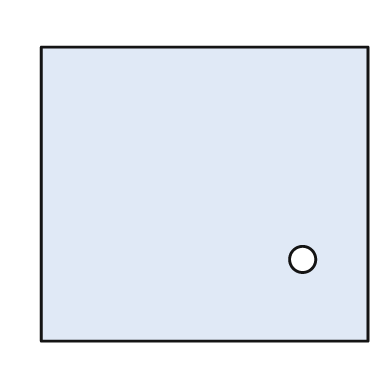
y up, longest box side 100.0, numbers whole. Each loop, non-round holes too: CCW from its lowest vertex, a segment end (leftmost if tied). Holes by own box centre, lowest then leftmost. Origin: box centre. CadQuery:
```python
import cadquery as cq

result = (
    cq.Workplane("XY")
    .moveTo(-50.0, -45.0)
    .lineTo(50.0, -45.0)
    .lineTo(50.0, 45.0)
    .lineTo(-50.0, 45.0)
    .close()
    .moveTo(30.0, -20.0)
    .circle(4.0)
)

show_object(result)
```